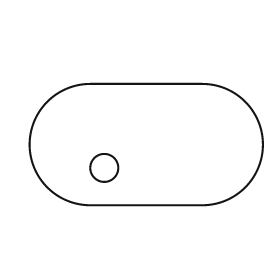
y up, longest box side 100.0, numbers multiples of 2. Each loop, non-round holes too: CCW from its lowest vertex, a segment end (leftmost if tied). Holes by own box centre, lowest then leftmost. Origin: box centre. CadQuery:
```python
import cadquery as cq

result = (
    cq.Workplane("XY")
    .moveTo(-24.0, -26.0)
    .lineTo(24.0, -26.0)
    .threePointArc((50.0, 0.0), (24.0, 26.0))
    .lineTo(-24.0, 26.0)
    .threePointArc((-50.0, 0.0), (-24.0, -26.0))
    .close()
    .moveTo(-18.0, -10.0)
    .circle(6.0)
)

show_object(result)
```